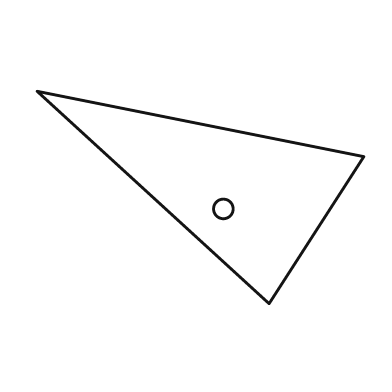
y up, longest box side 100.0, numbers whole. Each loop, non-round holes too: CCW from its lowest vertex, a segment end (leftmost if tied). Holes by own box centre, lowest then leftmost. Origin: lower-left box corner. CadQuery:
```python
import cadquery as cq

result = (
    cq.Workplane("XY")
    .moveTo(71.0, 0.0)
    .lineTo(100.0, 45.0)
    .lineTo(0.0, 65.0)
    .close()
    .moveTo(57.0, 29.0)
    .circle(3.0)
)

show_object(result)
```